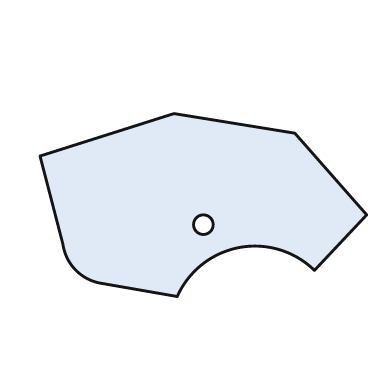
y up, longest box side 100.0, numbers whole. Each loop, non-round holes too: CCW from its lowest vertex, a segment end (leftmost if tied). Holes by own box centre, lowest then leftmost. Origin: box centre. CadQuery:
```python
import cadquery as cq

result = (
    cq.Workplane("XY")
    .moveTo(-8.0, -28.0)
    .threePointArc((11.0, -13.0), (34.0, -20.0))
    .lineTo(50.0, -3.0)
    .lineTo(28.0, 22.0)
    .lineTo(-9.0, 28.0)
    .lineTo(-50.0, 15.0)
    .lineTo(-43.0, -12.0)
    .threePointArc((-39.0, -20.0), (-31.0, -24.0))
    .close()
    .moveTo(0.0, -6.0)
    .circle(3.0)
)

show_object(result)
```